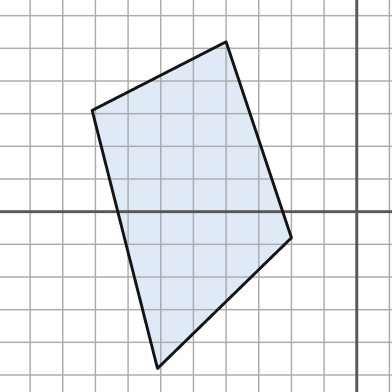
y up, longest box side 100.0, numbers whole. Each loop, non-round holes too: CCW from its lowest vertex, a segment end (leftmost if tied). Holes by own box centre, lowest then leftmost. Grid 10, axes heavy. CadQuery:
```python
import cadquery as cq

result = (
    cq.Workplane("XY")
    .moveTo(-61.0, -48.0)
    .lineTo(-20.0, -8.0)
    .lineTo(-40.0, 52.0)
    .lineTo(-81.0, 31.0)
    .close()
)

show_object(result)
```